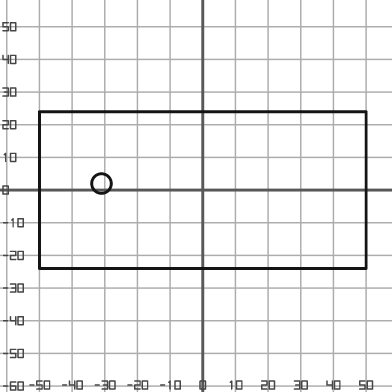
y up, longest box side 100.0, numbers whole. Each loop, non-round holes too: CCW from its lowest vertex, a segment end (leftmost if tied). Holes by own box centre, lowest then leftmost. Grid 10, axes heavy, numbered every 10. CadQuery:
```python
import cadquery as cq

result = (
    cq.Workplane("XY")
    .moveTo(-50.0, -24.0)
    .lineTo(50.0, -24.0)
    .lineTo(50.0, 24.0)
    .lineTo(-50.0, 24.0)
    .close()
    .moveTo(-31.0, 2.0)
    .circle(3.0)
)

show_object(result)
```